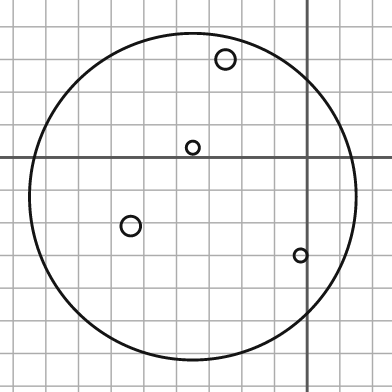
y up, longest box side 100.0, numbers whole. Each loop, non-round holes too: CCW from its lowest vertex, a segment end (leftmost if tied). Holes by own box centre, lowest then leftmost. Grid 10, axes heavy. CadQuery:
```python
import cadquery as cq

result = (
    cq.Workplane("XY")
    .moveTo(-35.0, -12.0)
    .circle(50.0)
    .moveTo(-2.0, -30.0)
    .circle(2.0)
    .moveTo(-54.0, -21.0)
    .circle(3.0)
    .moveTo(-35.0, 3.0)
    .circle(2.0)
    .moveTo(-25.0, 30.0)
    .circle(3.0)
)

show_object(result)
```